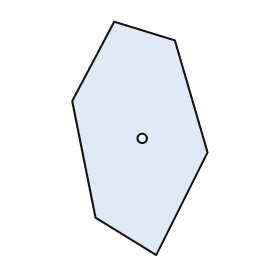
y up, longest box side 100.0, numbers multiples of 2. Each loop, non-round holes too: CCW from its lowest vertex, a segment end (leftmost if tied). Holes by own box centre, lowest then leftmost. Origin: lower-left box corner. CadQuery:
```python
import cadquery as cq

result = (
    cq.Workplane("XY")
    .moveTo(36.0, 0.0)
    .lineTo(58.0, 44.0)
    .lineTo(44.0, 92.0)
    .lineTo(18.0, 100.0)
    .lineTo(0.0, 66.0)
    .lineTo(10.0, 16.0)
    .close()
    .moveTo(30.0, 50.0)
    .circle(2.0)
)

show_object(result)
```